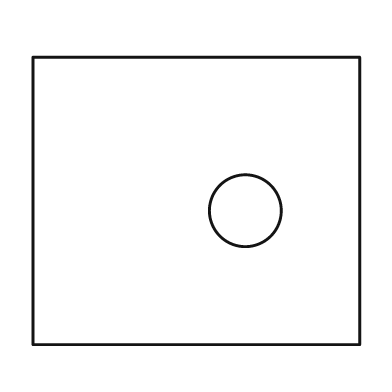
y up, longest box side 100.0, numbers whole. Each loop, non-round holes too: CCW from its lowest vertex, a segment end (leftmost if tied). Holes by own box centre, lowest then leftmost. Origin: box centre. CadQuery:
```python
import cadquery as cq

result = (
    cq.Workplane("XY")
    .moveTo(-50.0, -44.0)
    .lineTo(50.0, -44.0)
    .lineTo(50.0, 44.0)
    .lineTo(-50.0, 44.0)
    .close()
    .moveTo(15.0, -3.0)
    .circle(11.0)
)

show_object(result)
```